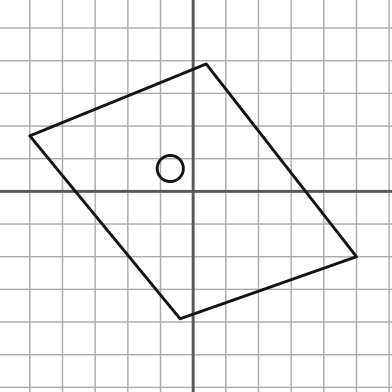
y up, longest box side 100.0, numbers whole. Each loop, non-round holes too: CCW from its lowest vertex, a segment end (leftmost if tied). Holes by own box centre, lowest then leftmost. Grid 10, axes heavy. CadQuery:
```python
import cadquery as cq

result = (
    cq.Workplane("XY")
    .moveTo(-4.0, -39.0)
    .lineTo(50.0, -20.0)
    .lineTo(4.0, 39.0)
    .lineTo(-50.0, 17.0)
    .close()
    .moveTo(-7.0, 7.0)
    .circle(4.0)
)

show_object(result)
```